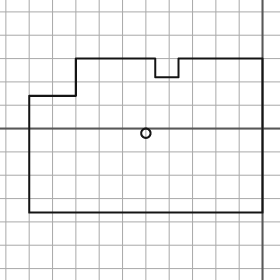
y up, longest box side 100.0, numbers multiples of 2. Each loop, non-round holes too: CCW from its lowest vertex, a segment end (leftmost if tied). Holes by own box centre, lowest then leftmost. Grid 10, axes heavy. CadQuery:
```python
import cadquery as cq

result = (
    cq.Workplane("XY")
    .moveTo(-100.0, -36.0)
    .lineTo(0.0, -36.0)
    .lineTo(0.0, 30.0)
    .lineTo(-36.0, 30.0)
    .lineTo(-36.0, 22.0)
    .lineTo(-46.0, 22.0)
    .lineTo(-46.0, 30.0)
    .lineTo(-80.0, 30.0)
    .lineTo(-80.0, 14.0)
    .lineTo(-100.0, 14.0)
    .close()
    .moveTo(-50.0, -2.0)
    .circle(2.0)
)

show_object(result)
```